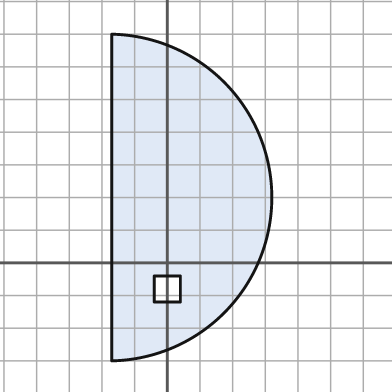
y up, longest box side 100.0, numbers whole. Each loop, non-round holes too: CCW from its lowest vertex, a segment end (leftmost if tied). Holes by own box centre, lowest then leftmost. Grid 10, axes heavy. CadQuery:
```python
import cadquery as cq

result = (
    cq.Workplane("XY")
    .moveTo(-17.0, -30.0)
    .threePointArc((32.0, 20.0), (-17.0, 70.0))
    .close()
    .moveTo(-4.0, -12.0)
    .lineTo(4.0, -12.0)
    .lineTo(4.0, -4.0)
    .lineTo(-4.0, -4.0)
    .close()
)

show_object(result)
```